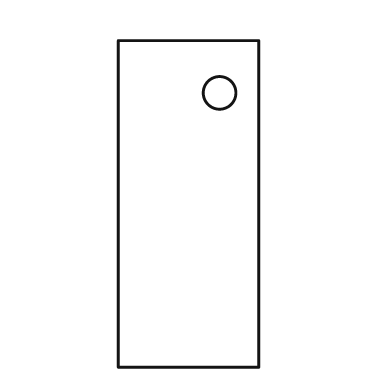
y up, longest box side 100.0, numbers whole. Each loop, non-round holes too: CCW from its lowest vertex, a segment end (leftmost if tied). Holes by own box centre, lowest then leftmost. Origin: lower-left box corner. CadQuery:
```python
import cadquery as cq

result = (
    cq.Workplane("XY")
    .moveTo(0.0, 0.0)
    .lineTo(43.0, 0.0)
    .lineTo(43.0, 100.0)
    .lineTo(0.0, 100.0)
    .close()
    .moveTo(31.0, 84.0)
    .circle(5.0)
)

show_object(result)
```